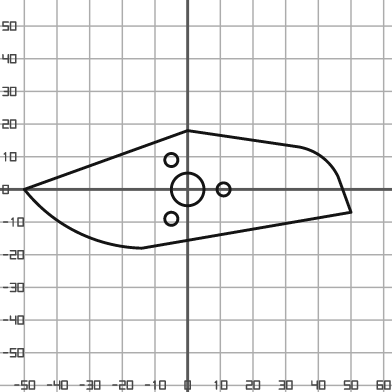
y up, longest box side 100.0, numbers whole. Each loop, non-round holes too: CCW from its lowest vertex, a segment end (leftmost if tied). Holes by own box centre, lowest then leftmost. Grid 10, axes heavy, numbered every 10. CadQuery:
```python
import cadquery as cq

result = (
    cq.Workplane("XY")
    .moveTo(-14.0, -18.0)
    .lineTo(50.0, -7.0)
    .lineTo(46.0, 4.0)
    .threePointArc((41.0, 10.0), (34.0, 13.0))
    .lineTo(0.0, 18.0)
    .lineTo(-50.0, 0.0)
    .threePointArc((-34.0, -13.0), (-14.0, -18.0))
    .close()
    .moveTo(-5.0, -9.0)
    .circle(2.0)
    .moveTo(0.0, 0.0)
    .circle(5.0)
    .moveTo(11.0, 0.0)
    .circle(2.0)
    .moveTo(-5.0, 9.0)
    .circle(2.0)
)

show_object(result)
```